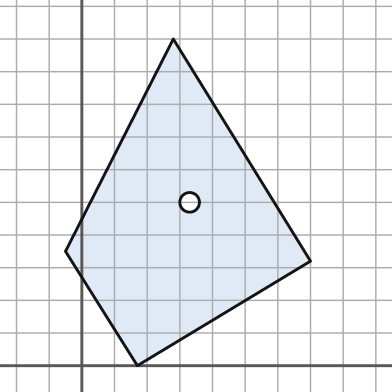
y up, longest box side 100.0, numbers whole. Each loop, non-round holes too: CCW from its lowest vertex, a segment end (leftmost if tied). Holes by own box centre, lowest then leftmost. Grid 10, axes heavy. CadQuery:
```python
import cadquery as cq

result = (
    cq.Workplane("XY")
    .moveTo(17.0, 0.0)
    .lineTo(70.0, 32.0)
    .lineTo(28.0, 100.0)
    .lineTo(-5.0, 35.0)
    .close()
    .moveTo(33.0, 50.0)
    .circle(3.0)
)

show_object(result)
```